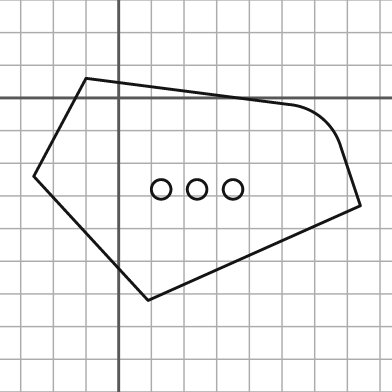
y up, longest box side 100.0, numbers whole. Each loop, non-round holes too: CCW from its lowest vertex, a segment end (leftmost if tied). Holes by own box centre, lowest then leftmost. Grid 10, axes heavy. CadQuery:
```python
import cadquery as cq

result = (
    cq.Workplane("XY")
    .moveTo(9.0, -62.0)
    .lineTo(74.0, -33.0)
    .lineTo(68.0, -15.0)
    .threePointArc((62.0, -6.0), (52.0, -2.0))
    .lineTo(-10.0, 6.0)
    .lineTo(-26.0, -24.0)
    .close()
    .moveTo(13.0, -28.0)
    .circle(3.0)
    .moveTo(24.0, -28.0)
    .circle(3.0)
    .moveTo(35.0, -28.0)
    .circle(3.0)
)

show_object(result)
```